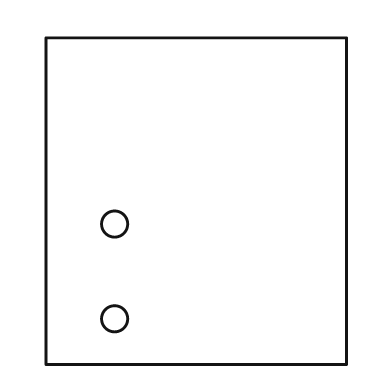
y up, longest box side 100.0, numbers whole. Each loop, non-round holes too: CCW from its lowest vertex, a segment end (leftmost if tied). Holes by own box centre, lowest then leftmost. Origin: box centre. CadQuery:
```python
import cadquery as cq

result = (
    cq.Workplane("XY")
    .moveTo(-46.0, -50.0)
    .lineTo(46.0, -50.0)
    .lineTo(46.0, 50.0)
    .lineTo(-46.0, 50.0)
    .close()
    .moveTo(-25.0, -36.0)
    .circle(4.0)
    .moveTo(-25.0, -7.0)
    .circle(4.0)
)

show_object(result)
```